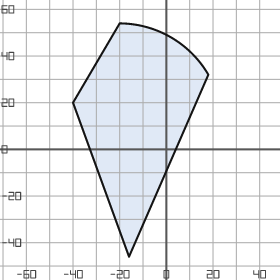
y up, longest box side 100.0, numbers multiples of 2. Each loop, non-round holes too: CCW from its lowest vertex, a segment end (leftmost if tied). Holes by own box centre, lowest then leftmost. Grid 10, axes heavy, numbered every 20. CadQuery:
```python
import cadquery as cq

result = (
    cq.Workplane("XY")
    .moveTo(-16.0, -46.0)
    .lineTo(18.0, 32.0)
    .threePointArc((2.0, 48.0), (-20.0, 54.0))
    .lineTo(-40.0, 20.0)
    .close()
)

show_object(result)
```